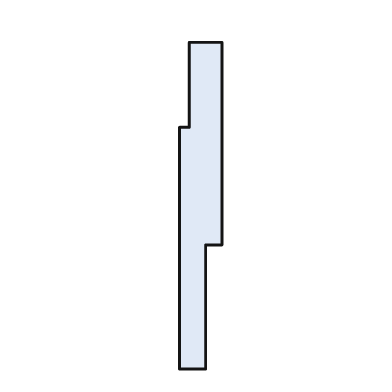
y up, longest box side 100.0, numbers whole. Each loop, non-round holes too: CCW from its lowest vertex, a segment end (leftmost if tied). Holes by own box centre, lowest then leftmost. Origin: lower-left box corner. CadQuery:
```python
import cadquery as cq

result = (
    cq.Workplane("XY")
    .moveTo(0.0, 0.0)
    .lineTo(8.0, 0.0)
    .lineTo(8.0, 38.0)
    .lineTo(13.0, 38.0)
    .lineTo(13.0, 100.0)
    .lineTo(3.0, 100.0)
    .lineTo(3.0, 74.0)
    .lineTo(0.0, 74.0)
    .close()
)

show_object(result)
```